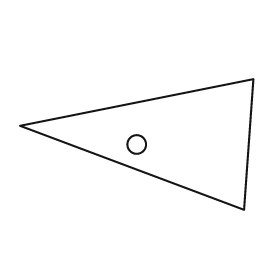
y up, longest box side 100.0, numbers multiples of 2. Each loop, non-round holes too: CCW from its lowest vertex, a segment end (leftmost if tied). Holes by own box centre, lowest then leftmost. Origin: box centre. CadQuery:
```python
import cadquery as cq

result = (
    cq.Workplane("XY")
    .moveTo(46.0, -28.0)
    .lineTo(50.0, 28.0)
    .lineTo(-50.0, 8.0)
    .close()
    .moveTo(0.0, 0.0)
    .circle(4.0)
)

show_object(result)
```